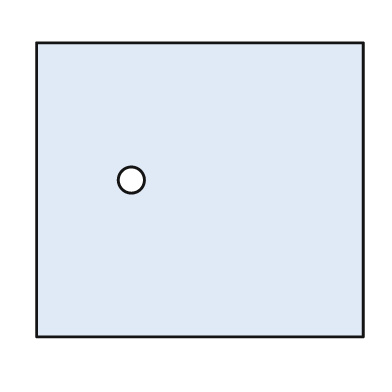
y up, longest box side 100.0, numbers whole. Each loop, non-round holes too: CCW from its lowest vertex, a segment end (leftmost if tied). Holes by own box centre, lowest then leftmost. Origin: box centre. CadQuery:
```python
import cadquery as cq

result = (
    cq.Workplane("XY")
    .moveTo(-50.0, -45.0)
    .lineTo(50.0, -45.0)
    .lineTo(50.0, 45.0)
    .lineTo(-50.0, 45.0)
    .close()
    .moveTo(-21.0, 3.0)
    .circle(4.0)
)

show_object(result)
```